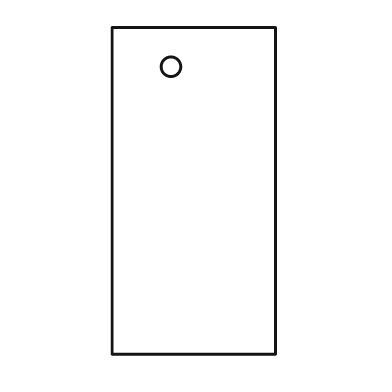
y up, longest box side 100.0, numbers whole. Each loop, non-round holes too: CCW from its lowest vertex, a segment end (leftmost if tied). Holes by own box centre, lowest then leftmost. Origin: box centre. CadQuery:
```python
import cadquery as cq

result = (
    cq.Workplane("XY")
    .moveTo(-25.0, -50.0)
    .lineTo(25.0, -50.0)
    .lineTo(25.0, 50.0)
    .lineTo(-25.0, 50.0)
    .close()
    .moveTo(-7.0, 38.0)
    .circle(3.0)
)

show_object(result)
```